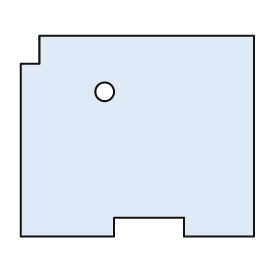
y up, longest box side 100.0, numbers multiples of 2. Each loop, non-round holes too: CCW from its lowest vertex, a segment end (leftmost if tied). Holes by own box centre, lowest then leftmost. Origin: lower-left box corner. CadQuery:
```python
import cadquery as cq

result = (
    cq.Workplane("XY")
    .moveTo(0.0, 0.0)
    .lineTo(40.0, 0.0)
    .lineTo(40.0, 8.0)
    .lineTo(70.0, 8.0)
    .lineTo(70.0, 0.0)
    .lineTo(100.0, 0.0)
    .lineTo(100.0, 86.0)
    .lineTo(8.0, 86.0)
    .lineTo(8.0, 74.0)
    .lineTo(0.0, 74.0)
    .close()
    .moveTo(36.0, 62.0)
    .circle(4.0)
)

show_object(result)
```